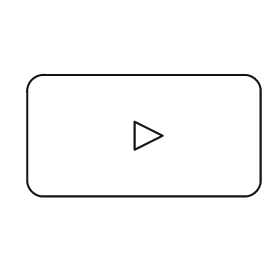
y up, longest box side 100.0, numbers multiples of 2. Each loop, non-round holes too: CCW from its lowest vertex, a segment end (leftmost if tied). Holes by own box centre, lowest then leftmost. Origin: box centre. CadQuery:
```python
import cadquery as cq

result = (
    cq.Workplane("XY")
    .moveTo(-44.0, -26.0)
    .lineTo(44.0, -26.0)
    .threePointArc((48.0, -24.0), (50.0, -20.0))
    .lineTo(50.0, 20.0)
    .threePointArc((48.0, 24.0), (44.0, 26.0))
    .lineTo(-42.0, 26.0)
    .threePointArc((-48.0, 24.0), (-50.0, 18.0))
    .lineTo(-50.0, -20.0)
    .threePointArc((-48.0, -24.0), (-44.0, -26.0))
    .close()
    .moveTo(-4.0, -6.0)
    .lineTo(8.0, 0.0)
    .lineTo(-4.0, 6.0)
    .close()
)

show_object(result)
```